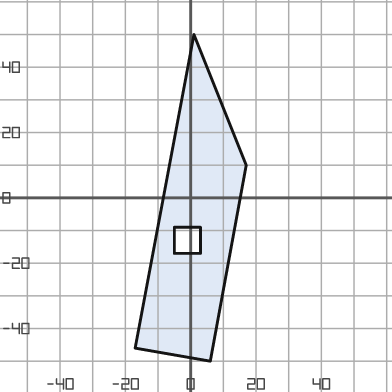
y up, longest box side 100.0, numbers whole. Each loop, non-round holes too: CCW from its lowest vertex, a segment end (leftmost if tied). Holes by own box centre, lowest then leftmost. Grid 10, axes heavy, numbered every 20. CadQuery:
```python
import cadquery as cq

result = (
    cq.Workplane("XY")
    .moveTo(6.0, -50.0)
    .lineTo(17.0, 10.0)
    .lineTo(1.0, 50.0)
    .lineTo(-17.0, -46.0)
    .close()
    .moveTo(-5.0, -17.0)
    .lineTo(3.0, -17.0)
    .lineTo(3.0, -9.0)
    .lineTo(-5.0, -9.0)
    .close()
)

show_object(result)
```